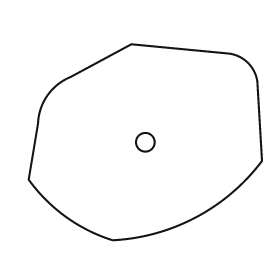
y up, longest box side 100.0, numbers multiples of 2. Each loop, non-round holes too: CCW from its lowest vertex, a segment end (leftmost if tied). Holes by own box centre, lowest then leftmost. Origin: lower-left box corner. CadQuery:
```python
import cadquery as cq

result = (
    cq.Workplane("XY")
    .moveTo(36.0, 0.0)
    .threePointArc((72.0, 10.0), (100.0, 34.0))
    .lineTo(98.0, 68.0)
    .threePointArc((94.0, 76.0), (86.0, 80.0))
    .lineTo(44.0, 84.0)
    .lineTo(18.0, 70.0)
    .threePointArc((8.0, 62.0), (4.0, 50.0))
    .lineTo(0.0, 26.0)
    .threePointArc((16.0, 10.0), (36.0, 0.0))
    .close()
    .moveTo(50.0, 42.0)
    .circle(4.0)
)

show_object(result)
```